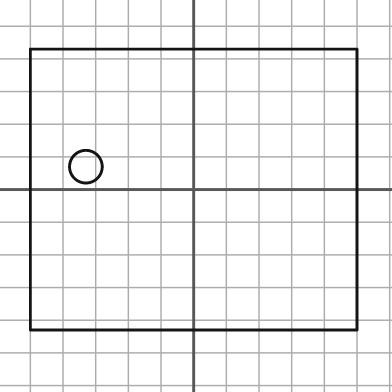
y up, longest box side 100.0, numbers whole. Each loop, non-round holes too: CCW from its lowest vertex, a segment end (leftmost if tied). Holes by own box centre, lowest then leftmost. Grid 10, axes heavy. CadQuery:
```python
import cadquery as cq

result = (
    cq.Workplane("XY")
    .moveTo(-50.0, -43.0)
    .lineTo(50.0, -43.0)
    .lineTo(50.0, 43.0)
    .lineTo(-50.0, 43.0)
    .close()
    .moveTo(-33.0, 7.0)
    .circle(5.0)
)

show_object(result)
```